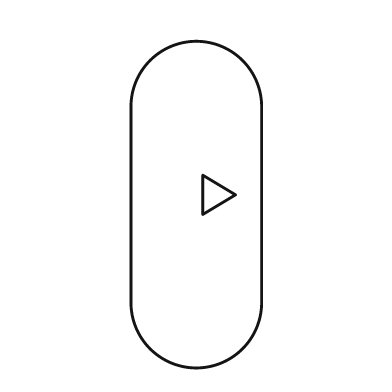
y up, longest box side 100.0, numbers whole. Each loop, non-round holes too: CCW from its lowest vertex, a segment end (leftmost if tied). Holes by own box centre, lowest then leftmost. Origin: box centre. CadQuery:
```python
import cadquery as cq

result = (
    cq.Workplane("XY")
    .moveTo(-20.0, -30.0)
    .threePointArc((0.0, -50.0), (20.0, -30.0))
    .lineTo(20.0, 30.0)
    .threePointArc((0.0, 50.0), (-20.0, 30.0))
    .close()
    .moveTo(2.0, -3.0)
    .lineTo(12.0, 3.0)
    .lineTo(2.0, 9.0)
    .close()
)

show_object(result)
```